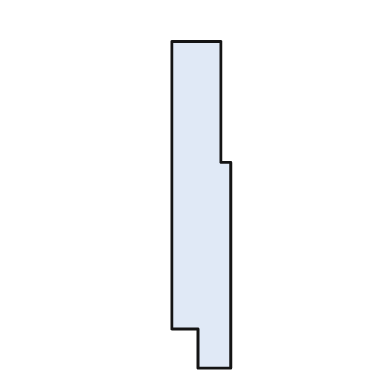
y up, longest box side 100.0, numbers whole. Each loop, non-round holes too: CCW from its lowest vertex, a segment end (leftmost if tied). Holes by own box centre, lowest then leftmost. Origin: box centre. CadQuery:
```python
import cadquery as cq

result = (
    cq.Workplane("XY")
    .moveTo(-1.0, -50.0)
    .lineTo(9.0, -50.0)
    .lineTo(9.0, 13.0)
    .lineTo(6.0, 13.0)
    .lineTo(6.0, 50.0)
    .lineTo(-9.0, 50.0)
    .lineTo(-9.0, -38.0)
    .lineTo(-1.0, -38.0)
    .close()
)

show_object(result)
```